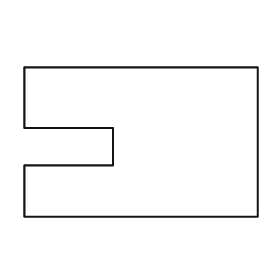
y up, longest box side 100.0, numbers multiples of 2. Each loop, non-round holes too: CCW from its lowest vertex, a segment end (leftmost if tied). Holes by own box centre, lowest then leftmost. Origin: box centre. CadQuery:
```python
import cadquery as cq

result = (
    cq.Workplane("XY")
    .moveTo(-50.0, -32.0)
    .lineTo(50.0, -32.0)
    .lineTo(50.0, 32.0)
    .lineTo(-50.0, 32.0)
    .lineTo(-50.0, 6.0)
    .lineTo(-12.0, 6.0)
    .lineTo(-12.0, -10.0)
    .lineTo(-50.0, -10.0)
    .close()
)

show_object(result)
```